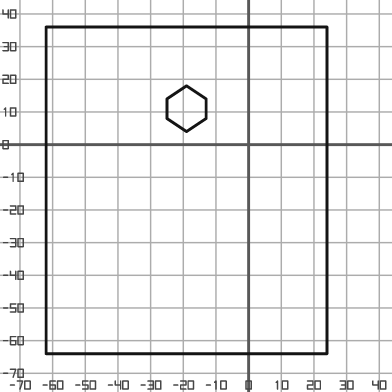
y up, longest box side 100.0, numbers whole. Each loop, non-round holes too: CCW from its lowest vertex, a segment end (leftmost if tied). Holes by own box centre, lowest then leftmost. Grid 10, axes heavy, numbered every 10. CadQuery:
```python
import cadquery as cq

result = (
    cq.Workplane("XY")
    .moveTo(-62.0, -64.0)
    .lineTo(24.0, -64.0)
    .lineTo(24.0, 36.0)
    .lineTo(-62.0, 36.0)
    .close()
    .moveTo(-19.0, 4.0)
    .lineTo(-13.0, 8.0)
    .lineTo(-13.0, 14.0)
    .lineTo(-19.0, 18.0)
    .lineTo(-25.0, 14.0)
    .lineTo(-25.0, 8.0)
    .close()
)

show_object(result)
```